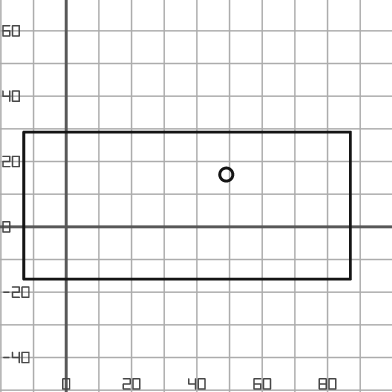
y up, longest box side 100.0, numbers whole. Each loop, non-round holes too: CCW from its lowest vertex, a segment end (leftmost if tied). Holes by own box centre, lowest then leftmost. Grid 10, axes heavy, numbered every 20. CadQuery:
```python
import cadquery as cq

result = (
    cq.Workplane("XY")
    .moveTo(-13.0, -16.0)
    .lineTo(87.0, -16.0)
    .lineTo(87.0, 29.0)
    .lineTo(-13.0, 29.0)
    .close()
    .moveTo(49.0, 16.0)
    .circle(2.0)
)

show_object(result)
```